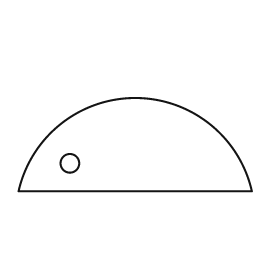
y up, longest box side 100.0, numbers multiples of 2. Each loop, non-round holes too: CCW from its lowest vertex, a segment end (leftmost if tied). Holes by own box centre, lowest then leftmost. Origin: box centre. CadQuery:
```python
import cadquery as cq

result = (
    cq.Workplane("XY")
    .moveTo(-50.0, -20.0)
    .lineTo(50.0, -20.0)
    .threePointArc((0.0, 20.0), (-50.0, -20.0))
    .close()
    .moveTo(-28.0, -8.0)
    .circle(4.0)
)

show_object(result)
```